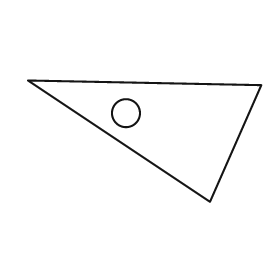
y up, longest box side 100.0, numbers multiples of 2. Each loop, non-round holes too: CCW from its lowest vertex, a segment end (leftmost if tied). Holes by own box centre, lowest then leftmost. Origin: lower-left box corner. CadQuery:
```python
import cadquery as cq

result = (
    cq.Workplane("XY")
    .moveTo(78.0, 0.0)
    .lineTo(100.0, 50.0)
    .lineTo(0.0, 52.0)
    .close()
    .moveTo(42.0, 38.0)
    .circle(6.0)
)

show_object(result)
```